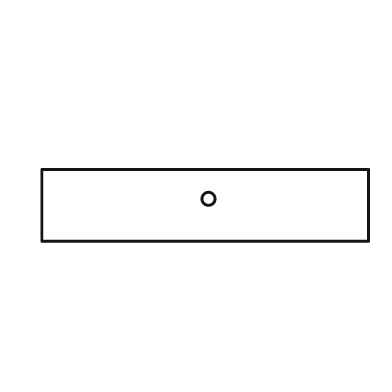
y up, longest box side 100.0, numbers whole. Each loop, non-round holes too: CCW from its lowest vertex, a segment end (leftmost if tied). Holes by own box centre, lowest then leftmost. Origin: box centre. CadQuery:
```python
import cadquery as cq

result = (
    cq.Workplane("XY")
    .moveTo(-50.0, -11.0)
    .lineTo(50.0, -11.0)
    .lineTo(50.0, 11.0)
    .lineTo(-50.0, 11.0)
    .close()
    .moveTo(1.0, 2.0)
    .circle(2.0)
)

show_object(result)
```